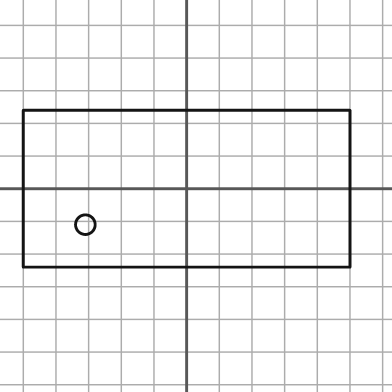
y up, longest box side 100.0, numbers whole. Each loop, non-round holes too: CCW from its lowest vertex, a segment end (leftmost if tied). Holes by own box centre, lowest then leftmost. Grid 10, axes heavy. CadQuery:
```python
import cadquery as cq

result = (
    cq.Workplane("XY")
    .moveTo(-50.0, -24.0)
    .lineTo(50.0, -24.0)
    .lineTo(50.0, 24.0)
    .lineTo(-50.0, 24.0)
    .close()
    .moveTo(-31.0, -11.0)
    .circle(3.0)
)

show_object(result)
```